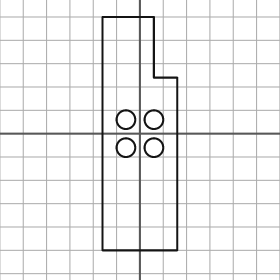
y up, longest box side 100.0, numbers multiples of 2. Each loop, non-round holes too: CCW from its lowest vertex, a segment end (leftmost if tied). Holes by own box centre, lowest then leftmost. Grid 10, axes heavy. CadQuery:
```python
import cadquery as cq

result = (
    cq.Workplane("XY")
    .moveTo(-16.0, -50.0)
    .lineTo(16.0, -50.0)
    .lineTo(16.0, 24.0)
    .lineTo(6.0, 24.0)
    .lineTo(6.0, 50.0)
    .lineTo(-16.0, 50.0)
    .close()
    .moveTo(-6.0, -6.0)
    .circle(4.0)
    .moveTo(6.0, -6.0)
    .circle(4.0)
    .moveTo(-6.0, 6.0)
    .circle(4.0)
    .moveTo(6.0, 6.0)
    .circle(4.0)
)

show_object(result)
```